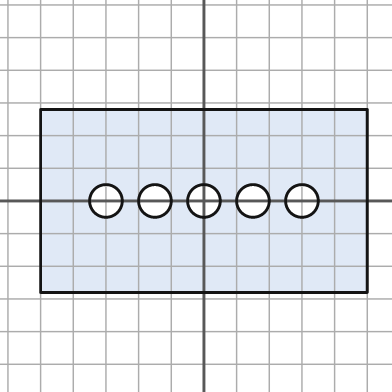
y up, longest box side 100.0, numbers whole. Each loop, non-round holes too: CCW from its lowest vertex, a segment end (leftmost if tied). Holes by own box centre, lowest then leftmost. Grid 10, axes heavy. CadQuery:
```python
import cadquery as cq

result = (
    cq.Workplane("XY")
    .moveTo(-50.0, -28.0)
    .lineTo(50.0, -28.0)
    .lineTo(50.0, 28.0)
    .lineTo(-50.0, 28.0)
    .close()
    .moveTo(-30.0, 0.0)
    .circle(5.0)
    .moveTo(-15.0, 0.0)
    .circle(5.0)
    .moveTo(0.0, 0.0)
    .circle(5.0)
    .moveTo(15.0, 0.0)
    .circle(5.0)
    .moveTo(30.0, 0.0)
    .circle(5.0)
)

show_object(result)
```